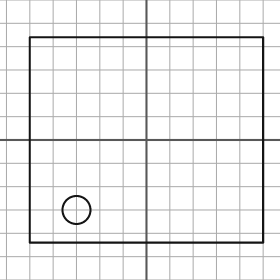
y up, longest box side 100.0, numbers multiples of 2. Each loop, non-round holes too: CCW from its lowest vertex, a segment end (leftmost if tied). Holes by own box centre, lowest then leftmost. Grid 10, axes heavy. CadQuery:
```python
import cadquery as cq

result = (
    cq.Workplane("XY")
    .moveTo(-50.0, -44.0)
    .lineTo(50.0, -44.0)
    .lineTo(50.0, 44.0)
    .lineTo(-50.0, 44.0)
    .close()
    .moveTo(-30.0, -30.0)
    .circle(6.0)
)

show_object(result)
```